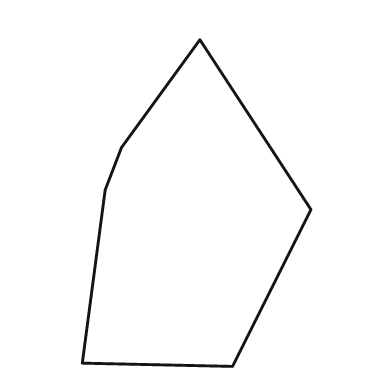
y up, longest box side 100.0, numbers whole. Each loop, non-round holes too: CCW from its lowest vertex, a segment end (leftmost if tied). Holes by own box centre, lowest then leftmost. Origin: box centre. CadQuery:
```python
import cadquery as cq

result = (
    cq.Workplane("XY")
    .moveTo(11.0, -50.0)
    .lineTo(35.0, -2.0)
    .lineTo(1.0, 50.0)
    .lineTo(-23.0, 17.0)
    .lineTo(-28.0, 4.0)
    .lineTo(-35.0, -49.0)
    .close()
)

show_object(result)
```